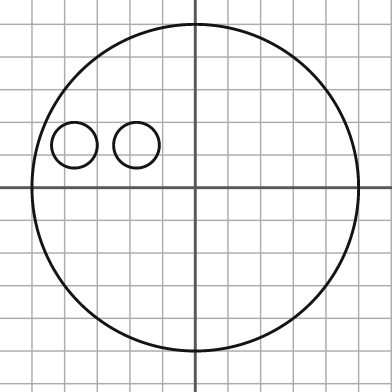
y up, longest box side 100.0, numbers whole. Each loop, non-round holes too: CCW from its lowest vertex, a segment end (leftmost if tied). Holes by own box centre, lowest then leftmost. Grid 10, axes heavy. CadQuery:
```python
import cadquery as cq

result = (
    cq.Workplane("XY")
    .moveTo(0.0, 0.0)
    .circle(50.0)
    .moveTo(-37.0, 13.0)
    .circle(7.0)
    .moveTo(-18.0, 13.0)
    .circle(7.0)
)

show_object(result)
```